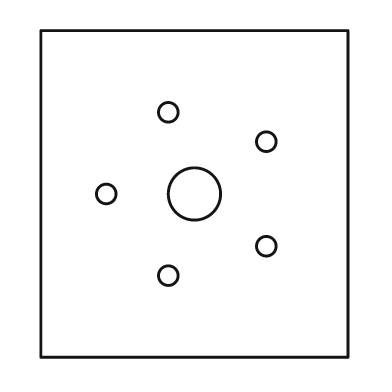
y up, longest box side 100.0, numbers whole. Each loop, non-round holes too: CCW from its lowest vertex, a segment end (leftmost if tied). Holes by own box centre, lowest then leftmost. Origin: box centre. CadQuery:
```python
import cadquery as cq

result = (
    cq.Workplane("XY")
    .moveTo(-47.0, -50.0)
    .lineTo(47.0, -50.0)
    .lineTo(47.0, 50.0)
    .lineTo(-47.0, 50.0)
    .close()
    .moveTo(-8.0, -25.0)
    .circle(3.0)
    .moveTo(22.0, -16.0)
    .circle(3.0)
    .moveTo(-27.0, 0.0)
    .circle(3.0)
    .moveTo(0.0, 0.0)
    .circle(8.0)
    .moveTo(22.0, 16.0)
    .circle(3.0)
    .moveTo(-8.0, 25.0)
    .circle(3.0)
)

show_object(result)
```